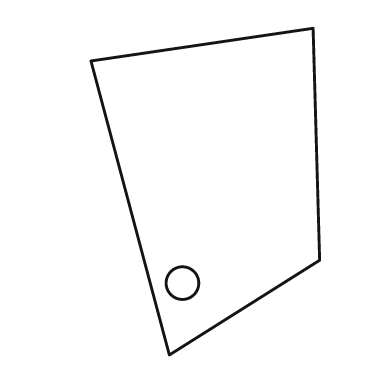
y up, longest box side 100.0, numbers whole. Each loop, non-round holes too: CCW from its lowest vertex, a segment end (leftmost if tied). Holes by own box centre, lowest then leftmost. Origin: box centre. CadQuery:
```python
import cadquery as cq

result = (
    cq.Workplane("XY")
    .moveTo(-11.0, -50.0)
    .lineTo(35.0, -21.0)
    .lineTo(33.0, 50.0)
    .lineTo(-35.0, 40.0)
    .close()
    .moveTo(-7.0, -28.0)
    .circle(5.0)
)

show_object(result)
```